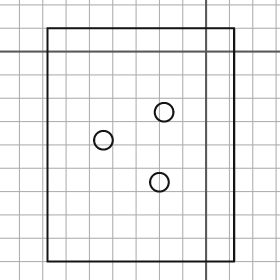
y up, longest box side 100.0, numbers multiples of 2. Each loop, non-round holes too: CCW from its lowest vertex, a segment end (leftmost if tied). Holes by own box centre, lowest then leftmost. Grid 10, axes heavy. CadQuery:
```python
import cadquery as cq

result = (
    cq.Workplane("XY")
    .moveTo(-68.0, -90.0)
    .lineTo(12.0, -90.0)
    .lineTo(12.0, 10.0)
    .lineTo(-68.0, 10.0)
    .close()
    .moveTo(-20.0, -56.0)
    .circle(4.0)
    .moveTo(-44.0, -38.0)
    .circle(4.0)
    .moveTo(-18.0, -26.0)
    .circle(4.0)
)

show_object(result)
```